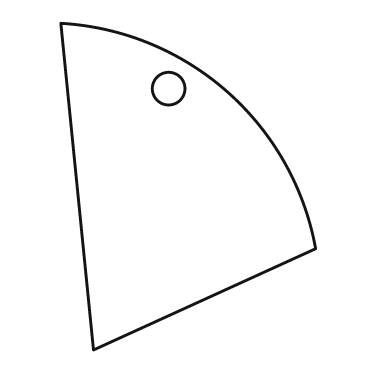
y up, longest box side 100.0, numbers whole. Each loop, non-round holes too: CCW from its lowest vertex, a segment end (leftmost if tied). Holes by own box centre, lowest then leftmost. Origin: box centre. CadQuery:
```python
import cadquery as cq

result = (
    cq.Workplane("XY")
    .moveTo(-29.0, -50.0)
    .lineTo(39.0, -19.0)
    .threePointArc((12.0, 29.0), (-39.0, 50.0))
    .close()
    .moveTo(-6.0, 30.0)
    .circle(5.0)
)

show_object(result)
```